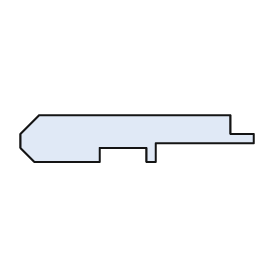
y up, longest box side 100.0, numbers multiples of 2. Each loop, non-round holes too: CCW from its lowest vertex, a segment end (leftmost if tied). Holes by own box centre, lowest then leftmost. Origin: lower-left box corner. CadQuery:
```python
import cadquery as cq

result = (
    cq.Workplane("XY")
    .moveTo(6.0, 0.0)
    .lineTo(34.0, 0.0)
    .lineTo(34.0, 6.0)
    .lineTo(54.0, 6.0)
    .lineTo(54.0, 0.0)
    .lineTo(58.0, 0.0)
    .lineTo(58.0, 8.0)
    .lineTo(100.0, 8.0)
    .lineTo(100.0, 12.0)
    .lineTo(90.0, 12.0)
    .lineTo(90.0, 20.0)
    .lineTo(8.0, 20.0)
    .lineTo(0.0, 12.0)
    .lineTo(0.0, 6.0)
    .close()
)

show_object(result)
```